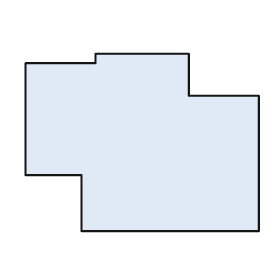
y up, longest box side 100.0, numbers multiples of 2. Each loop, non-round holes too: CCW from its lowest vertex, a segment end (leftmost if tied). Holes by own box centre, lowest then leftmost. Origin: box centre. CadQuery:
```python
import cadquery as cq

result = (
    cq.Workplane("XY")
    .moveTo(-26.0, -38.0)
    .lineTo(50.0, -38.0)
    .lineTo(50.0, 20.0)
    .lineTo(20.0, 20.0)
    .lineTo(20.0, 38.0)
    .lineTo(-20.0, 38.0)
    .lineTo(-20.0, 34.0)
    .lineTo(-50.0, 34.0)
    .lineTo(-50.0, -14.0)
    .lineTo(-26.0, -14.0)
    .close()
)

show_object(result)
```